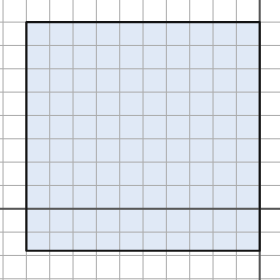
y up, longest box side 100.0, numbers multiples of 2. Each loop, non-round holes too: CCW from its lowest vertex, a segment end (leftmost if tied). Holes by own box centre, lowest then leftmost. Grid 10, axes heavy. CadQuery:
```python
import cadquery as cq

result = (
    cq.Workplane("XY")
    .moveTo(-100.0, -18.0)
    .lineTo(0.0, -18.0)
    .lineTo(0.0, 80.0)
    .lineTo(-100.0, 80.0)
    .close()
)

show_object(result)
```